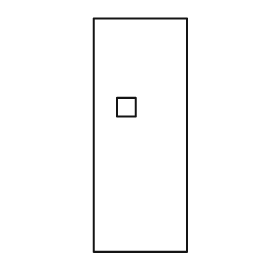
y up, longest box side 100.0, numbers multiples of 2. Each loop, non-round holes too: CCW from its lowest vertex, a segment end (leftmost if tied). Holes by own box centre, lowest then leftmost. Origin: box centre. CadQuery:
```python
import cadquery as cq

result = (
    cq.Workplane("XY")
    .moveTo(-20.0, -50.0)
    .lineTo(20.0, -50.0)
    .lineTo(20.0, 50.0)
    .lineTo(-20.0, 50.0)
    .close()
    .moveTo(-10.0, 8.0)
    .lineTo(-2.0, 8.0)
    .lineTo(-2.0, 16.0)
    .lineTo(-10.0, 16.0)
    .close()
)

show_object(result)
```